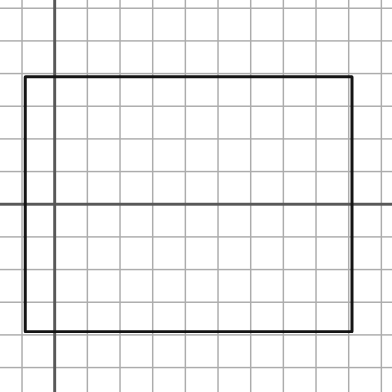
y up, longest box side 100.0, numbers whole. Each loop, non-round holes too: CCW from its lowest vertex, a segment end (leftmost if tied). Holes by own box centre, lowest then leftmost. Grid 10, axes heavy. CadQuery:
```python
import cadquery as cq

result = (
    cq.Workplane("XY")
    .moveTo(-9.0, -39.0)
    .lineTo(91.0, -39.0)
    .lineTo(91.0, 39.0)
    .lineTo(-9.0, 39.0)
    .close()
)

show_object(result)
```